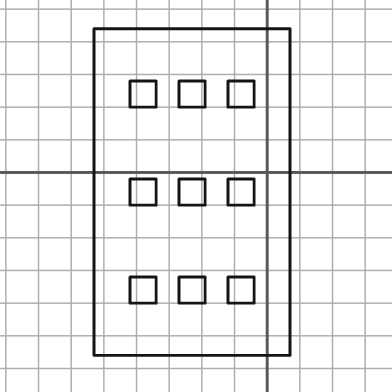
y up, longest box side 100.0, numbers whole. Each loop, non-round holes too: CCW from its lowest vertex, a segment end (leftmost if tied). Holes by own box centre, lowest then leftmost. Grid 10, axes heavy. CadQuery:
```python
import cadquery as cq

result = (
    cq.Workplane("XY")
    .moveTo(-53.0, -56.0)
    .lineTo(7.0, -56.0)
    .lineTo(7.0, 44.0)
    .lineTo(-53.0, 44.0)
    .close()
    .moveTo(-42.0, -40.0)
    .lineTo(-34.0, -40.0)
    .lineTo(-34.0, -32.0)
    .lineTo(-42.0, -32.0)
    .close()
    .moveTo(-27.0, -40.0)
    .lineTo(-19.0, -40.0)
    .lineTo(-19.0, -32.0)
    .lineTo(-27.0, -32.0)
    .close()
    .moveTo(-12.0, -40.0)
    .lineTo(-4.0, -40.0)
    .lineTo(-4.0, -32.0)
    .lineTo(-12.0, -32.0)
    .close()
    .moveTo(-42.0, -10.0)
    .lineTo(-34.0, -10.0)
    .lineTo(-34.0, -2.0)
    .lineTo(-42.0, -2.0)
    .close()
    .moveTo(-27.0, -10.0)
    .lineTo(-19.0, -10.0)
    .lineTo(-19.0, -2.0)
    .lineTo(-27.0, -2.0)
    .close()
    .moveTo(-12.0, -10.0)
    .lineTo(-4.0, -10.0)
    .lineTo(-4.0, -2.0)
    .lineTo(-12.0, -2.0)
    .close()
    .moveTo(-42.0, 20.0)
    .lineTo(-34.0, 20.0)
    .lineTo(-34.0, 28.0)
    .lineTo(-42.0, 28.0)
    .close()
    .moveTo(-27.0, 20.0)
    .lineTo(-19.0, 20.0)
    .lineTo(-19.0, 28.0)
    .lineTo(-27.0, 28.0)
    .close()
    .moveTo(-12.0, 20.0)
    .lineTo(-4.0, 20.0)
    .lineTo(-4.0, 28.0)
    .lineTo(-12.0, 28.0)
    .close()
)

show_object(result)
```